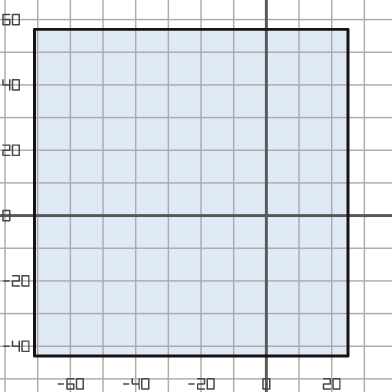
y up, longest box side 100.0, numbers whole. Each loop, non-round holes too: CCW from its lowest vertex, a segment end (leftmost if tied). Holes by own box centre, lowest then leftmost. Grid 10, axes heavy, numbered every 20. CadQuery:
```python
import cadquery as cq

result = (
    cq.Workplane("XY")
    .moveTo(-71.0, -43.0)
    .lineTo(25.0, -43.0)
    .lineTo(25.0, 57.0)
    .lineTo(-71.0, 57.0)
    .close()
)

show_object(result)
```